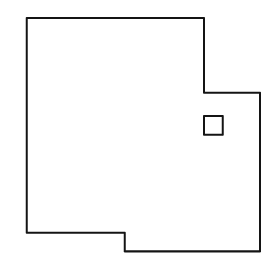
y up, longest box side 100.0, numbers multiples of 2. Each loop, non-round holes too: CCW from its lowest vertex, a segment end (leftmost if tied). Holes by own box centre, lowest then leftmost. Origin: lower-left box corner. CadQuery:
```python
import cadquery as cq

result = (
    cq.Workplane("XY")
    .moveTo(42.0, 0.0)
    .lineTo(100.0, 0.0)
    .lineTo(100.0, 68.0)
    .lineTo(76.0, 68.0)
    .lineTo(76.0, 100.0)
    .lineTo(0.0, 100.0)
    .lineTo(0.0, 8.0)
    .lineTo(42.0, 8.0)
    .close()
    .moveTo(76.0, 50.0)
    .lineTo(84.0, 50.0)
    .lineTo(84.0, 58.0)
    .lineTo(76.0, 58.0)
    .close()
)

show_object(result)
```